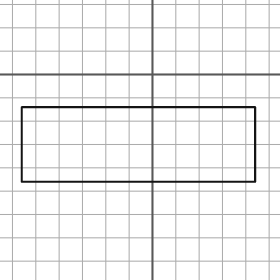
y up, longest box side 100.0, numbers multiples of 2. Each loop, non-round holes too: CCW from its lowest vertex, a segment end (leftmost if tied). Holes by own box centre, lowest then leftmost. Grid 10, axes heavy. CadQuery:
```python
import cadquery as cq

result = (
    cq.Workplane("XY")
    .moveTo(-56.0, -46.0)
    .lineTo(44.0, -46.0)
    .lineTo(44.0, -14.0)
    .lineTo(-56.0, -14.0)
    .close()
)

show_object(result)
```